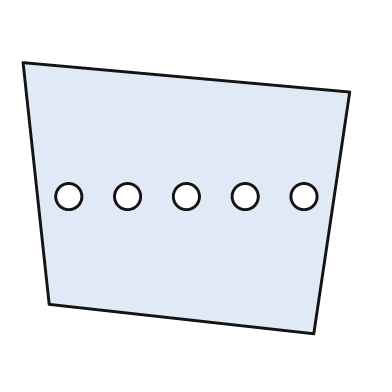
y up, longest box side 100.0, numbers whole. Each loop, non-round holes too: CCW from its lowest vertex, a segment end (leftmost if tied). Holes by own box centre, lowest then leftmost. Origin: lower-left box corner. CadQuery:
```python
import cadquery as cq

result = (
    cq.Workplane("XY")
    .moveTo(89.0, 0.0)
    .lineTo(100.0, 74.0)
    .lineTo(0.0, 83.0)
    .lineTo(8.0, 9.0)
    .close()
    .moveTo(14.0, 42.0)
    .circle(4.0)
    .moveTo(32.0, 42.0)
    .circle(4.0)
    .moveTo(50.0, 42.0)
    .circle(4.0)
    .moveTo(68.0, 42.0)
    .circle(4.0)
    .moveTo(86.0, 42.0)
    .circle(4.0)
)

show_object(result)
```